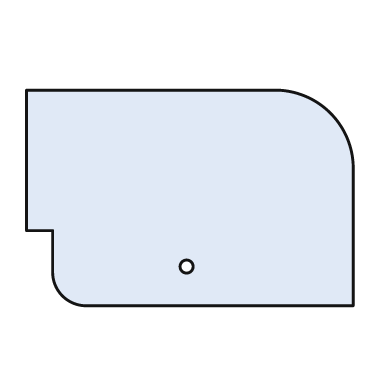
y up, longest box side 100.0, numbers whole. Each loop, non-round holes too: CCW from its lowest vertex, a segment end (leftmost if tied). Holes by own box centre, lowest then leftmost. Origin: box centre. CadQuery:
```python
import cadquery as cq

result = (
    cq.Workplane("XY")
    .moveTo(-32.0, -33.0)
    .lineTo(50.0, -33.0)
    .lineTo(50.0, 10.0)
    .threePointArc((43.0, 26.0), (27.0, 33.0))
    .lineTo(-50.0, 33.0)
    .lineTo(-50.0, -10.0)
    .lineTo(-42.0, -10.0)
    .lineTo(-42.0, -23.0)
    .threePointArc((-39.0, -30.0), (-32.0, -33.0))
    .close()
    .moveTo(-1.0, -21.0)
    .circle(2.0)
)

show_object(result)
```